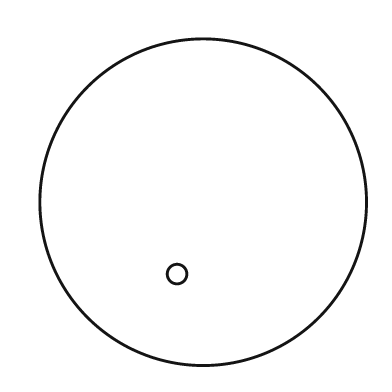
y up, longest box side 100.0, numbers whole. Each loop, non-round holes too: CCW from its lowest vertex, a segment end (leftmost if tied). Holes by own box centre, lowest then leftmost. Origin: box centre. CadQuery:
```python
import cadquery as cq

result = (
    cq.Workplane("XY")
    .moveTo(0.0, 0.0)
    .circle(50.0)
    .moveTo(-8.0, -22.0)
    .circle(3.0)
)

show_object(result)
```